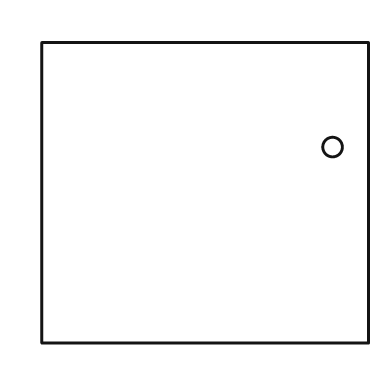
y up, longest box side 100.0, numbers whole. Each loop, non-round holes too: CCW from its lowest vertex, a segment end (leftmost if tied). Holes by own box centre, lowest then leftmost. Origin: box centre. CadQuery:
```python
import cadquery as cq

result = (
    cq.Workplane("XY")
    .moveTo(-50.0, -46.0)
    .lineTo(50.0, -46.0)
    .lineTo(50.0, 46.0)
    .lineTo(-50.0, 46.0)
    .close()
    .moveTo(39.0, 14.0)
    .circle(3.0)
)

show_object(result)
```